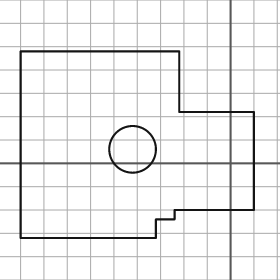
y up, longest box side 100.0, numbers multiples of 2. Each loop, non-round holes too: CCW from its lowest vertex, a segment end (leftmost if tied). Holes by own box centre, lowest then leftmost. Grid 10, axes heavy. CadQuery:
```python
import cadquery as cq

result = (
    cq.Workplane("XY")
    .moveTo(-90.0, -32.0)
    .lineTo(-32.0, -32.0)
    .lineTo(-32.0, -24.0)
    .lineTo(-24.0, -24.0)
    .lineTo(-24.0, -20.0)
    .lineTo(10.0, -20.0)
    .lineTo(10.0, 22.0)
    .lineTo(-22.0, 22.0)
    .lineTo(-22.0, 48.0)
    .lineTo(-90.0, 48.0)
    .close()
    .moveTo(-42.0, 6.0)
    .circle(10.0)
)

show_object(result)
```